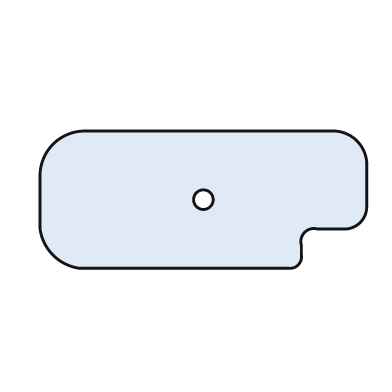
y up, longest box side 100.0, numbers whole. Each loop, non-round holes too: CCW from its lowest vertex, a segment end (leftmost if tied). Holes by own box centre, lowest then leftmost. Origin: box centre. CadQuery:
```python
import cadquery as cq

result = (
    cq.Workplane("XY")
    .moveTo(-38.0, -21.0)
    .lineTo(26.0, -21.0)
    .threePointArc((29.0, -20.0), (30.0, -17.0))
    .lineTo(30.0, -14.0)
    .threePointArc((31.0, -10.0), (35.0, -9.0))
    .lineTo(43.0, -9.0)
    .threePointArc((48.0, -7.0), (50.0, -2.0))
    .lineTo(50.0, 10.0)
    .threePointArc((47.0, 18.0), (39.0, 21.0))
    .lineTo(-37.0, 21.0)
    .threePointArc((-46.0, 17.0), (-50.0, 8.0))
    .lineTo(-50.0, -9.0)
    .threePointArc((-46.0, -17.0), (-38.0, -21.0))
    .close()
    .moveTo(0.0, 0.0)
    .circle(3.0)
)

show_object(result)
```